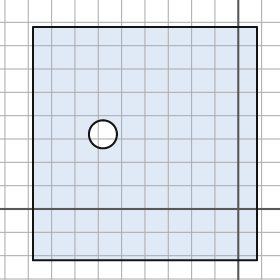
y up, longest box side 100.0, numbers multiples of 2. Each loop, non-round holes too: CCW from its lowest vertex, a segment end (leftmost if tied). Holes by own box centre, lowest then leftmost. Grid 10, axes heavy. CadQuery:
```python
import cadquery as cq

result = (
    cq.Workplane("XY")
    .moveTo(-88.0, -22.0)
    .lineTo(8.0, -22.0)
    .lineTo(8.0, 78.0)
    .lineTo(-88.0, 78.0)
    .close()
    .moveTo(-58.0, 32.0)
    .circle(6.0)
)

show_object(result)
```